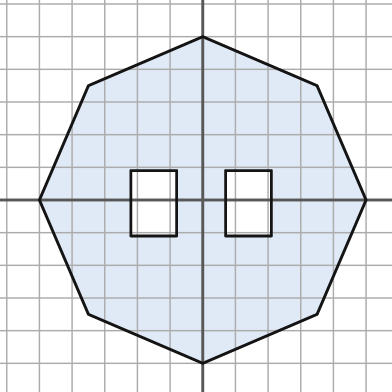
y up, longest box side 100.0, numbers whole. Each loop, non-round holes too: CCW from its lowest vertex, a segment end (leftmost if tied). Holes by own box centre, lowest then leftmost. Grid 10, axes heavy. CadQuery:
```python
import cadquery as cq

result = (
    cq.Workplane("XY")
    .moveTo(0.0, -50.0)
    .lineTo(35.0, -35.0)
    .lineTo(50.0, 0.0)
    .lineTo(35.0, 35.0)
    .lineTo(0.0, 50.0)
    .lineTo(-35.0, 35.0)
    .lineTo(-50.0, 0.0)
    .lineTo(-35.0, -35.0)
    .close()
    .moveTo(-22.0, -11.0)
    .lineTo(-8.0, -11.0)
    .lineTo(-8.0, 9.0)
    .lineTo(-22.0, 9.0)
    .close()
    .moveTo(7.0, -11.0)
    .lineTo(21.0, -11.0)
    .lineTo(21.0, 9.0)
    .lineTo(7.0, 9.0)
    .close()
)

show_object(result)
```